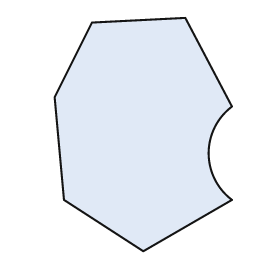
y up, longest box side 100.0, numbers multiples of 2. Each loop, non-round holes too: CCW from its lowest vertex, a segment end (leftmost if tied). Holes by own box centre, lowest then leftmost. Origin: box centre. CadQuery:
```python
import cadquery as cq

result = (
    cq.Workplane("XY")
    .moveTo(0.0, -50.0)
    .lineTo(38.0, -28.0)
    .threePointArc((28.0, -8.0), (38.0, 12.0))
    .lineTo(18.0, 50.0)
    .lineTo(-22.0, 48.0)
    .lineTo(-38.0, 16.0)
    .lineTo(-34.0, -28.0)
    .close()
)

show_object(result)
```